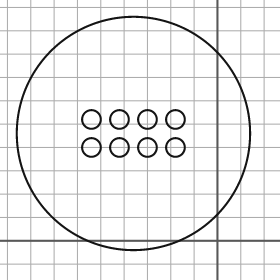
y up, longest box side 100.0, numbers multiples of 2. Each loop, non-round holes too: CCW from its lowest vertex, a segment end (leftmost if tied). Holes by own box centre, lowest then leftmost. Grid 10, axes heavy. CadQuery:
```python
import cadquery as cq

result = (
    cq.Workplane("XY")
    .moveTo(-36.0, 46.0)
    .circle(50.0)
    .moveTo(-54.0, 40.0)
    .circle(4.0)
    .moveTo(-42.0, 40.0)
    .circle(4.0)
    .moveTo(-30.0, 40.0)
    .circle(4.0)
    .moveTo(-18.0, 40.0)
    .circle(4.0)
    .moveTo(-54.0, 52.0)
    .circle(4.0)
    .moveTo(-42.0, 52.0)
    .circle(4.0)
    .moveTo(-30.0, 52.0)
    .circle(4.0)
    .moveTo(-18.0, 52.0)
    .circle(4.0)
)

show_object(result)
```